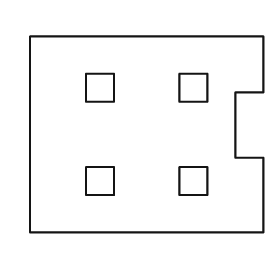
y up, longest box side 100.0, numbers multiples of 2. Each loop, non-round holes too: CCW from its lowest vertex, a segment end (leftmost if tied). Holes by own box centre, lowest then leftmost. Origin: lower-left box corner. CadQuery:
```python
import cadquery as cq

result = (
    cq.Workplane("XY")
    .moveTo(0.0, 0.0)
    .lineTo(100.0, 0.0)
    .lineTo(100.0, 32.0)
    .lineTo(88.0, 32.0)
    .lineTo(88.0, 60.0)
    .lineTo(100.0, 60.0)
    .lineTo(100.0, 84.0)
    .lineTo(0.0, 84.0)
    .close()
    .moveTo(24.0, 16.0)
    .lineTo(36.0, 16.0)
    .lineTo(36.0, 28.0)
    .lineTo(24.0, 28.0)
    .close()
    .moveTo(64.0, 16.0)
    .lineTo(76.0, 16.0)
    .lineTo(76.0, 28.0)
    .lineTo(64.0, 28.0)
    .close()
    .moveTo(24.0, 56.0)
    .lineTo(36.0, 56.0)
    .lineTo(36.0, 68.0)
    .lineTo(24.0, 68.0)
    .close()
    .moveTo(64.0, 56.0)
    .lineTo(76.0, 56.0)
    .lineTo(76.0, 68.0)
    .lineTo(64.0, 68.0)
    .close()
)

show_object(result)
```